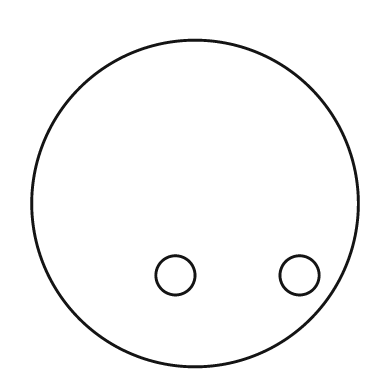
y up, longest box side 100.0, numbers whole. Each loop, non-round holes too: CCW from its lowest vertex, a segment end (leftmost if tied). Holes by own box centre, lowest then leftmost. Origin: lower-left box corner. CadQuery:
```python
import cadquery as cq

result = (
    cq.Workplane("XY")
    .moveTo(50.0, 50.0)
    .circle(50.0)
    .moveTo(44.0, 28.0)
    .circle(6.0)
    .moveTo(82.0, 28.0)
    .circle(6.0)
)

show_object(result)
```